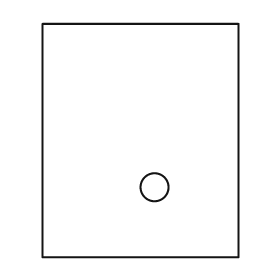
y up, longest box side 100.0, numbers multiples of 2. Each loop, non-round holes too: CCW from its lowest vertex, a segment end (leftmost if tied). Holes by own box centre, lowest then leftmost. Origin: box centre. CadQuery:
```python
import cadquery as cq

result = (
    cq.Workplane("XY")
    .moveTo(-42.0, -50.0)
    .lineTo(42.0, -50.0)
    .lineTo(42.0, 50.0)
    .lineTo(-42.0, 50.0)
    .close()
    .moveTo(6.0, -20.0)
    .circle(6.0)
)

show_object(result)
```